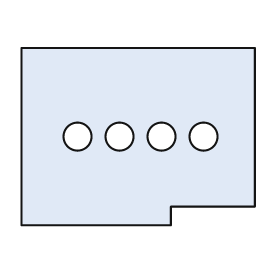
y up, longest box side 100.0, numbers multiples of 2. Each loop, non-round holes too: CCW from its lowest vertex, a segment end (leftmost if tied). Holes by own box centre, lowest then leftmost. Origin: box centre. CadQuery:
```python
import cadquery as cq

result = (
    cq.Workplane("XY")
    .moveTo(-50.0, -38.0)
    .lineTo(14.0, -38.0)
    .lineTo(14.0, -30.0)
    .lineTo(50.0, -30.0)
    .lineTo(50.0, 38.0)
    .lineTo(-50.0, 38.0)
    .close()
    .moveTo(-26.0, 0.0)
    .circle(6.0)
    .moveTo(-8.0, 0.0)
    .circle(6.0)
    .moveTo(10.0, 0.0)
    .circle(6.0)
    .moveTo(28.0, 0.0)
    .circle(6.0)
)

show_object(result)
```